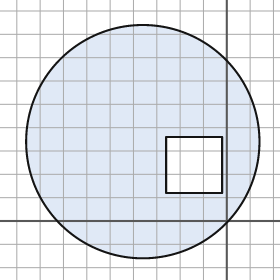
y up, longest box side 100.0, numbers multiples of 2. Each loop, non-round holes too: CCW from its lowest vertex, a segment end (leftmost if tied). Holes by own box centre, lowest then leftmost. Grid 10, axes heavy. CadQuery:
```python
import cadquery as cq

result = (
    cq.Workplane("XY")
    .moveTo(-36.0, 34.0)
    .circle(50.0)
    .moveTo(-26.0, 12.0)
    .lineTo(-2.0, 12.0)
    .lineTo(-2.0, 36.0)
    .lineTo(-26.0, 36.0)
    .close()
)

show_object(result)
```